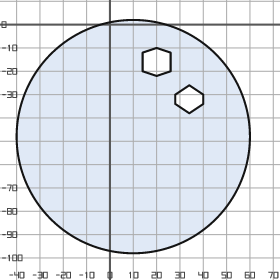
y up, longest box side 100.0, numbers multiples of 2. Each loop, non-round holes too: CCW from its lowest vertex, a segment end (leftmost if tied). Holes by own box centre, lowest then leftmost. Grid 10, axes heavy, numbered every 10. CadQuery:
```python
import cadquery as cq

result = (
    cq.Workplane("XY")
    .moveTo(10.0, -48.0)
    .circle(50.0)
    .moveTo(34.0, -38.0)
    .lineTo(40.0, -34.0)
    .lineTo(40.0, -30.0)
    .lineTo(34.0, -26.0)
    .lineTo(28.0, -30.0)
    .lineTo(28.0, -34.0)
    .close()
    .moveTo(20.0, -22.0)
    .lineTo(26.0, -20.0)
    .lineTo(26.0, -12.0)
    .lineTo(20.0, -10.0)
    .lineTo(14.0, -12.0)
    .lineTo(14.0, -20.0)
    .close()
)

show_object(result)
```